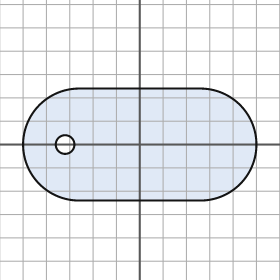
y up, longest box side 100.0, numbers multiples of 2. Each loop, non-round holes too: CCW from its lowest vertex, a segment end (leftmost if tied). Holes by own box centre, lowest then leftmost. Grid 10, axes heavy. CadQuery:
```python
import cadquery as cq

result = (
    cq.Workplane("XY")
    .moveTo(-26.0, -24.0)
    .lineTo(26.0, -24.0)
    .threePointArc((50.0, 0.0), (26.0, 24.0))
    .lineTo(-26.0, 24.0)
    .threePointArc((-50.0, 0.0), (-26.0, -24.0))
    .close()
    .moveTo(-32.0, 0.0)
    .circle(4.0)
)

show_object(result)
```